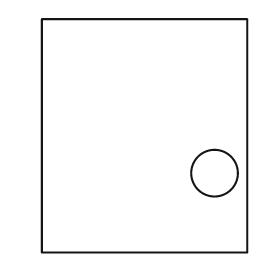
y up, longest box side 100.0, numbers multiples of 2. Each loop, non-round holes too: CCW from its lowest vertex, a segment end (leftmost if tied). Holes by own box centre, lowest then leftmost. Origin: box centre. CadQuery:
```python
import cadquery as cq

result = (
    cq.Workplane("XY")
    .moveTo(-44.0, -50.0)
    .lineTo(44.0, -50.0)
    .lineTo(44.0, 50.0)
    .lineTo(-44.0, 50.0)
    .close()
    .moveTo(30.0, -16.0)
    .circle(10.0)
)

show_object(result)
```